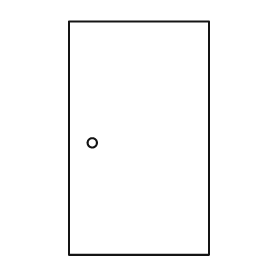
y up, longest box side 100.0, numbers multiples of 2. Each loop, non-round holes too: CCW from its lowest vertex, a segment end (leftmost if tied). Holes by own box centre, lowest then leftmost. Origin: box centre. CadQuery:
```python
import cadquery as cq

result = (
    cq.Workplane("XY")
    .moveTo(-30.0, -50.0)
    .lineTo(30.0, -50.0)
    .lineTo(30.0, 50.0)
    .lineTo(-30.0, 50.0)
    .close()
    .moveTo(-20.0, -2.0)
    .circle(2.0)
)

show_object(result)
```